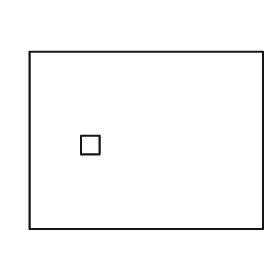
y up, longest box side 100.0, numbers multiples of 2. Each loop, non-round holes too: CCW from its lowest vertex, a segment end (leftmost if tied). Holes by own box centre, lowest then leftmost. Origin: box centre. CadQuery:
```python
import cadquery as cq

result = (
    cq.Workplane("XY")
    .moveTo(-50.0, -38.0)
    .lineTo(50.0, -38.0)
    .lineTo(50.0, 38.0)
    .lineTo(-50.0, 38.0)
    .close()
    .moveTo(-28.0, -6.0)
    .lineTo(-20.0, -6.0)
    .lineTo(-20.0, 2.0)
    .lineTo(-28.0, 2.0)
    .close()
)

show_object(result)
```